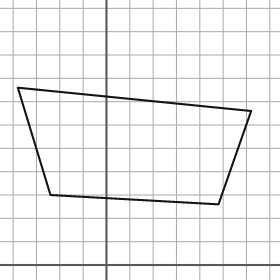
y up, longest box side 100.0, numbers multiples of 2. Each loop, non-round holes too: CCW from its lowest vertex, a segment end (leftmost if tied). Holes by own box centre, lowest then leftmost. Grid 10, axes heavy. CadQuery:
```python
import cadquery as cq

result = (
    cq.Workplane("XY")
    .moveTo(48.0, 26.0)
    .lineTo(62.0, 66.0)
    .lineTo(-38.0, 76.0)
    .lineTo(-24.0, 30.0)
    .close()
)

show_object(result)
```